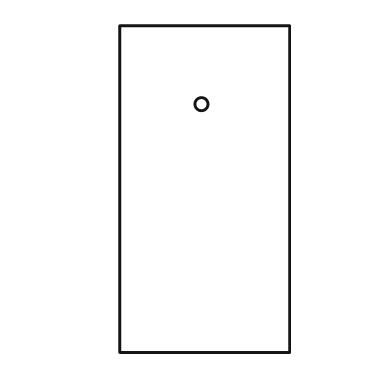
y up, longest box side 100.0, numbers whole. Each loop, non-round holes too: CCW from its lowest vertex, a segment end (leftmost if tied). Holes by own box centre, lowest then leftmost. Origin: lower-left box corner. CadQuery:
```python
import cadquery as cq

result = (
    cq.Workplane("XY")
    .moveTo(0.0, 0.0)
    .lineTo(52.0, 0.0)
    .lineTo(52.0, 100.0)
    .lineTo(0.0, 100.0)
    .close()
    .moveTo(25.0, 76.0)
    .circle(2.0)
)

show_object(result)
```